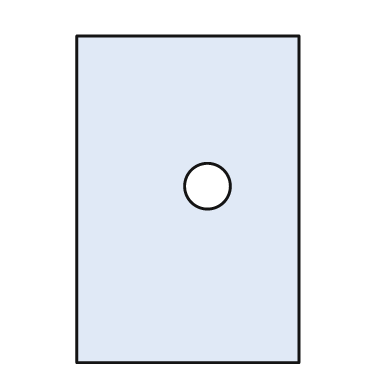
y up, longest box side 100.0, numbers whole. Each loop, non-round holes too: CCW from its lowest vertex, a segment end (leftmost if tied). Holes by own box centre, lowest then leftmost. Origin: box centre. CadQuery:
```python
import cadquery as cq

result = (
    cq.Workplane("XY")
    .moveTo(-34.0, -50.0)
    .lineTo(34.0, -50.0)
    .lineTo(34.0, 50.0)
    .lineTo(-34.0, 50.0)
    .close()
    .moveTo(6.0, 4.0)
    .circle(7.0)
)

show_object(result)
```